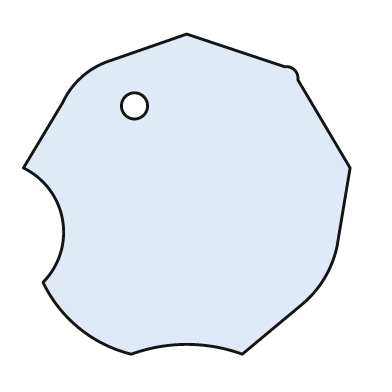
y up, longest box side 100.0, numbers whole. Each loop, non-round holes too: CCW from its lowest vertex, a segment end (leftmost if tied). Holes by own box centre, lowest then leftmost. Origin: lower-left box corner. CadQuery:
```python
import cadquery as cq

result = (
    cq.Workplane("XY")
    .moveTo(33.0, 0.0)
    .threePointArc((50.0, 3.0), (67.0, 0.0))
    .lineTo(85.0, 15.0)
    .threePointArc((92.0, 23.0), (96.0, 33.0))
    .lineTo(100.0, 57.0)
    .lineTo(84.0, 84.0)
    .threePointArc((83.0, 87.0), (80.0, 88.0))
    .lineTo(50.0, 98.0)
    .lineTo(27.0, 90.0)
    .threePointArc((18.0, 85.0), (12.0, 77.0))
    .lineTo(0.0, 57.0)
    .threePointArc((12.0, 41.0), (6.0, 22.0))
    .threePointArc((17.0, 8.0), (33.0, 0.0))
    .close()
    .moveTo(34.0, 76.0)
    .circle(4.0)
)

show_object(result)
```